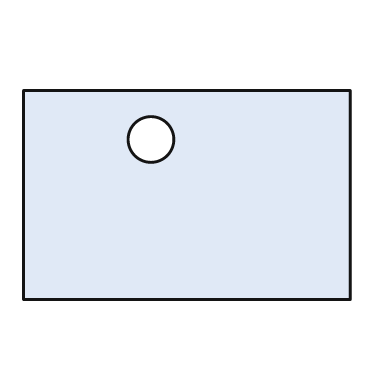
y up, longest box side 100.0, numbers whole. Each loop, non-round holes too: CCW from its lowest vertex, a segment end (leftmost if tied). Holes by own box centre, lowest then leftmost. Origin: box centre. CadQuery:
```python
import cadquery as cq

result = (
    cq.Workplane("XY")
    .moveTo(-50.0, -32.0)
    .lineTo(50.0, -32.0)
    .lineTo(50.0, 32.0)
    .lineTo(-50.0, 32.0)
    .close()
    .moveTo(-11.0, 17.0)
    .circle(7.0)
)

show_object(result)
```